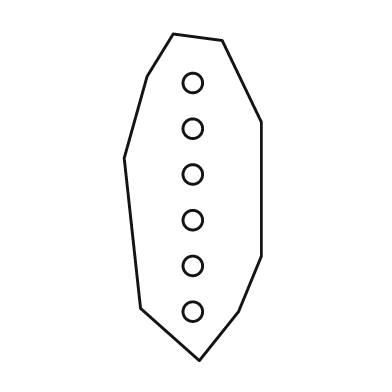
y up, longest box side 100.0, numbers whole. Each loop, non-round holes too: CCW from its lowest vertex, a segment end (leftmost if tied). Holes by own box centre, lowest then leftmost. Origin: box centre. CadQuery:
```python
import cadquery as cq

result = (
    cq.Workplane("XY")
    .moveTo(2.0, -50.0)
    .lineTo(14.0, -35.0)
    .lineTo(21.0, -18.0)
    .lineTo(21.0, 23.0)
    .lineTo(9.0, 48.0)
    .lineTo(-6.0, 50.0)
    .lineTo(-14.0, 37.0)
    .lineTo(-21.0, 12.0)
    .lineTo(-16.0, -34.0)
    .close()
    .moveTo(0.0, -35.0)
    .circle(3.0)
    .moveTo(0.0, -21.0)
    .circle(3.0)
    .moveTo(0.0, -7.0)
    .circle(3.0)
    .moveTo(0.0, 7.0)
    .circle(3.0)
    .moveTo(0.0, 21.0)
    .circle(3.0)
    .moveTo(0.0, 35.0)
    .circle(3.0)
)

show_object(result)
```